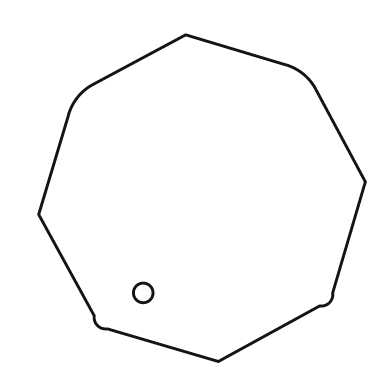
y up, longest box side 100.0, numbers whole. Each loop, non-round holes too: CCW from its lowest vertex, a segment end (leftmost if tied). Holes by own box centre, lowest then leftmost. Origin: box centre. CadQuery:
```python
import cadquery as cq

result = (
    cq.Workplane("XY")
    .moveTo(5.0, -50.0)
    .lineTo(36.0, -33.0)
    .threePointArc((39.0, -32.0), (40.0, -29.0))
    .lineTo(50.0, 5.0)
    .lineTo(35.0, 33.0)
    .threePointArc((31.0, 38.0), (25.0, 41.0))
    .lineTo(-5.0, 50.0)
    .lineTo(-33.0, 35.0)
    .threePointArc((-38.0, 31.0), (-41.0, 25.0))
    .lineTo(-50.0, -5.0)
    .lineTo(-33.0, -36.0)
    .threePointArc((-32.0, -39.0), (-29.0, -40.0))
    .close()
    .moveTo(-18.0, -29.0)
    .circle(3.0)
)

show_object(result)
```